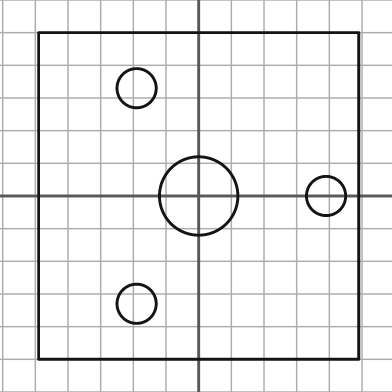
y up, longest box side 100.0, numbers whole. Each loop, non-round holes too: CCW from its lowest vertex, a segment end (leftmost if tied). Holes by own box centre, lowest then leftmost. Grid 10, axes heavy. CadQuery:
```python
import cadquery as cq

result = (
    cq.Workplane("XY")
    .moveTo(-49.0, -50.0)
    .lineTo(49.0, -50.0)
    .lineTo(49.0, 50.0)
    .lineTo(-49.0, 50.0)
    .close()
    .moveTo(-19.0, -33.0)
    .circle(6.0)
    .moveTo(0.0, 0.0)
    .circle(12.0)
    .moveTo(39.0, 0.0)
    .circle(6.0)
    .moveTo(-19.0, 33.0)
    .circle(6.0)
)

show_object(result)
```